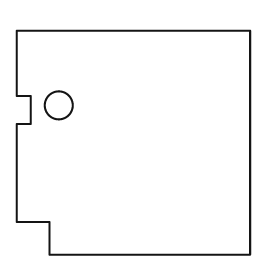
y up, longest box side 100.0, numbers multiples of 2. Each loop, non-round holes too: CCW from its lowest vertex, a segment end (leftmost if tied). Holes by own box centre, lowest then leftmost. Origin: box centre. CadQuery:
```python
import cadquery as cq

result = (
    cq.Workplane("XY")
    .moveTo(-36.0, -48.0)
    .lineTo(50.0, -48.0)
    .lineTo(50.0, 48.0)
    .lineTo(-50.0, 48.0)
    .lineTo(-50.0, 20.0)
    .lineTo(-44.0, 20.0)
    .lineTo(-44.0, 8.0)
    .lineTo(-50.0, 8.0)
    .lineTo(-50.0, -34.0)
    .lineTo(-36.0, -34.0)
    .close()
    .moveTo(-32.0, 16.0)
    .circle(6.0)
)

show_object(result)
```